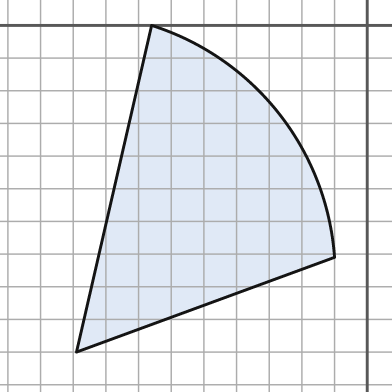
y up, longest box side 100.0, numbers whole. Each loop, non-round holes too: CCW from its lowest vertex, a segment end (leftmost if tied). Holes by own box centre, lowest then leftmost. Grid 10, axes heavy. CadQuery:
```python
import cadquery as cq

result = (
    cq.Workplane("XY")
    .moveTo(-89.0, -100.0)
    .lineTo(-10.0, -71.0)
    .threePointArc((-27.0, -27.0), (-66.0, 0.0))
    .close()
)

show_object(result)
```